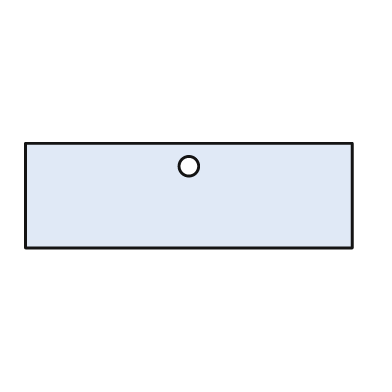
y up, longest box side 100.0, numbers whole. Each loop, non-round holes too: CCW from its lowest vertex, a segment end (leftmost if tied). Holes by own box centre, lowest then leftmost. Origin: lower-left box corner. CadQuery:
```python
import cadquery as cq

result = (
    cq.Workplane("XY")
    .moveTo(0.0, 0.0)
    .lineTo(100.0, 0.0)
    .lineTo(100.0, 32.0)
    .lineTo(0.0, 32.0)
    .close()
    .moveTo(50.0, 25.0)
    .circle(3.0)
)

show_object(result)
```